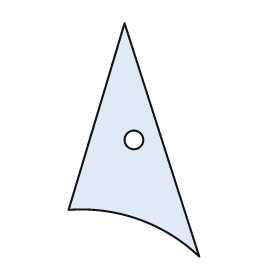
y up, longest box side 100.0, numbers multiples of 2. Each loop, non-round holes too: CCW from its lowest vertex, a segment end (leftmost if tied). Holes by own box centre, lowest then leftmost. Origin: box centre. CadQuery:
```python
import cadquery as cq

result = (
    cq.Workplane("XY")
    .moveTo(28.0, -50.0)
    .lineTo(-4.0, 50.0)
    .lineTo(-28.0, -30.0)
    .threePointArc((2.0, -34.0), (28.0, -50.0))
    .close()
    .moveTo(0.0, 0.0)
    .circle(4.0)
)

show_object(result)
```